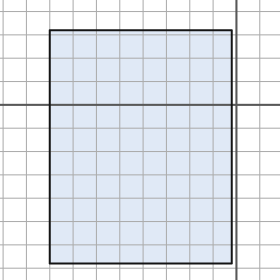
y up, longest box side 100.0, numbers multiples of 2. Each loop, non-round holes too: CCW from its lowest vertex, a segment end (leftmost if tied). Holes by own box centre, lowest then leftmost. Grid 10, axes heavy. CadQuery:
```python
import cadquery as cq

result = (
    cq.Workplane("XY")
    .moveTo(-80.0, -68.0)
    .lineTo(-2.0, -68.0)
    .lineTo(-2.0, 32.0)
    .lineTo(-80.0, 32.0)
    .close()
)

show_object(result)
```